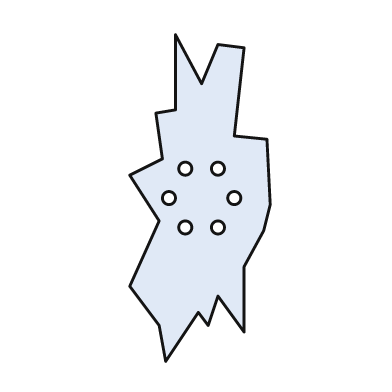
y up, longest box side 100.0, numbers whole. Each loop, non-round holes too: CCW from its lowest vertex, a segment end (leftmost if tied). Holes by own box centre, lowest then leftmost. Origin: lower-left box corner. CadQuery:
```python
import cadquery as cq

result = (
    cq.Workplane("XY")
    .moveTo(11.0, 0.0)
    .lineTo(21.0, 15.0)
    .lineTo(24.0, 11.0)
    .lineTo(27.0, 20.0)
    .lineTo(35.0, 9.0)
    .lineTo(35.0, 29.0)
    .lineTo(41.0, 40.0)
    .lineTo(43.0, 48.0)
    .lineTo(42.0, 68.0)
    .lineTo(32.0, 69.0)
    .lineTo(35.0, 96.0)
    .lineTo(27.0, 97.0)
    .lineTo(22.0, 85.0)
    .lineTo(14.0, 100.0)
    .lineTo(14.0, 77.0)
    .lineTo(8.0, 76.0)
    .lineTo(10.0, 62.0)
    .lineTo(0.0, 57.0)
    .lineTo(9.0, 43.0)
    .lineTo(0.0, 23.0)
    .lineTo(9.0, 11.0)
    .close()
    .moveTo(17.0, 41.0)
    .circle(2.0)
    .moveTo(27.0, 41.0)
    .circle(2.0)
    .moveTo(12.0, 50.0)
    .circle(2.0)
    .moveTo(32.0, 50.0)
    .circle(2.0)
    .moveTo(17.0, 59.0)
    .circle(2.0)
    .moveTo(27.0, 59.0)
    .circle(2.0)
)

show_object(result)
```